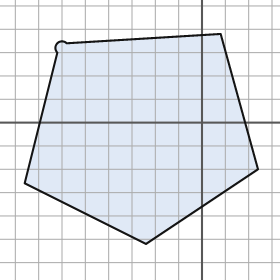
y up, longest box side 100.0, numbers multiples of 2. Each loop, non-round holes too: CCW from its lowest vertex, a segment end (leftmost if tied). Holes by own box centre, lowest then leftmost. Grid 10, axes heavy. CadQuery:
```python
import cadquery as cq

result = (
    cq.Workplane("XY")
    .moveTo(-24.0, -52.0)
    .lineTo(24.0, -20.0)
    .lineTo(8.0, 38.0)
    .lineTo(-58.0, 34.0)
    .threePointArc((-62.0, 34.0), (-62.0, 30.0))
    .lineTo(-76.0, -26.0)
    .close()
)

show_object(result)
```